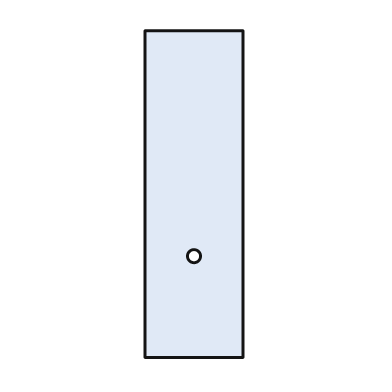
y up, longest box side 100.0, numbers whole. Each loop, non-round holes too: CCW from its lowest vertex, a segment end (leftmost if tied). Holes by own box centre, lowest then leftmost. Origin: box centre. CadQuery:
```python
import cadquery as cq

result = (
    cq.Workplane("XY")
    .moveTo(-15.0, -50.0)
    .lineTo(15.0, -50.0)
    .lineTo(15.0, 50.0)
    .lineTo(-15.0, 50.0)
    .close()
    .moveTo(0.0, -19.0)
    .circle(2.0)
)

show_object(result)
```